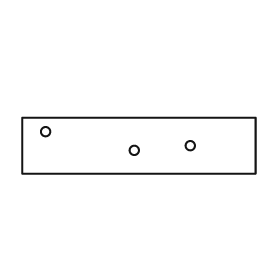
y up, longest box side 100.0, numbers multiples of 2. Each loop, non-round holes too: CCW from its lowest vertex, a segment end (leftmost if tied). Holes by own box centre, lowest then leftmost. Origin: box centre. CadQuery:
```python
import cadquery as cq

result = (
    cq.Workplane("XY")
    .moveTo(-50.0, -12.0)
    .lineTo(50.0, -12.0)
    .lineTo(50.0, 12.0)
    .lineTo(-50.0, 12.0)
    .close()
    .moveTo(-2.0, -2.0)
    .circle(2.0)
    .moveTo(22.0, 0.0)
    .circle(2.0)
    .moveTo(-40.0, 6.0)
    .circle(2.0)
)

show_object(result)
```